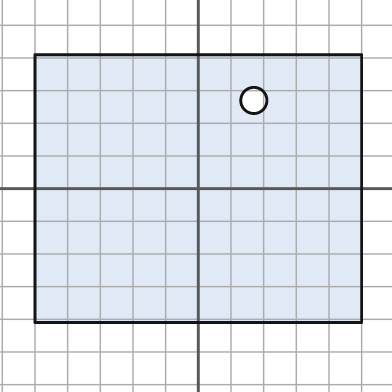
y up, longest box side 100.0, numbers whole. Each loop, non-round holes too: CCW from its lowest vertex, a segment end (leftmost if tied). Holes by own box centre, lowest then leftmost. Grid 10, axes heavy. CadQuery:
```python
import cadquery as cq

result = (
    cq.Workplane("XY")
    .moveTo(-50.0, -41.0)
    .lineTo(50.0, -41.0)
    .lineTo(50.0, 41.0)
    .lineTo(-50.0, 41.0)
    .close()
    .moveTo(17.0, 27.0)
    .circle(4.0)
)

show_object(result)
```